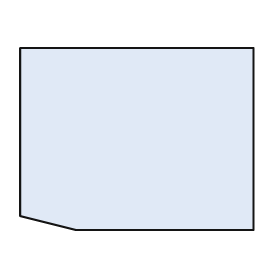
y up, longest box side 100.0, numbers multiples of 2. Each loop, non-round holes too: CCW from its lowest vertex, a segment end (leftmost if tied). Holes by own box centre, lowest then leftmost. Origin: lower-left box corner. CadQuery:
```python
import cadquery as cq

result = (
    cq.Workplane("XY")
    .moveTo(24.0, 0.0)
    .lineTo(100.0, 0.0)
    .lineTo(100.0, 78.0)
    .lineTo(0.0, 78.0)
    .lineTo(0.0, 6.0)
    .close()
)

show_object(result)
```